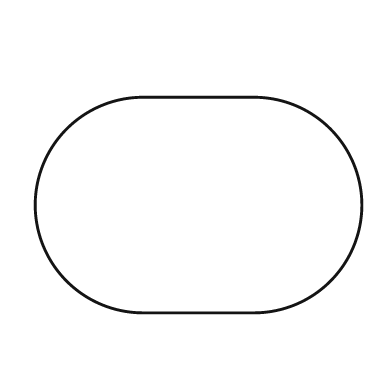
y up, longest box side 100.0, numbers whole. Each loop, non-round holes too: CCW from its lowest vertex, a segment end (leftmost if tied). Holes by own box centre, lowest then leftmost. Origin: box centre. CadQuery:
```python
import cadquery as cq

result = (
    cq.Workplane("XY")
    .moveTo(-17.0, -33.0)
    .lineTo(17.0, -33.0)
    .threePointArc((50.0, 0.0), (17.0, 33.0))
    .lineTo(-17.0, 33.0)
    .threePointArc((-50.0, 0.0), (-17.0, -33.0))
    .close()
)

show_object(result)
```